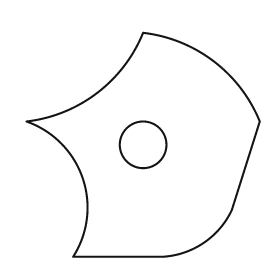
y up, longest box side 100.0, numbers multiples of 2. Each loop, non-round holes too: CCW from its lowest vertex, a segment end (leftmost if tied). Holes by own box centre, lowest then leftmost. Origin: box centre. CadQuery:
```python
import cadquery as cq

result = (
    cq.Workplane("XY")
    .moveTo(-30.0, -48.0)
    .lineTo(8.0, -48.0)
    .threePointArc((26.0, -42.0), (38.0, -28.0))
    .lineTo(50.0, 10.0)
    .threePointArc((30.0, 36.0), (0.0, 48.0))
    .threePointArc((-20.0, 22.0), (-50.0, 10.0))
    .threePointArc((-26.0, -14.0), (-30.0, -48.0))
    .close()
    .moveTo(0.0, 0.0)
    .circle(10.0)
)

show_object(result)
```